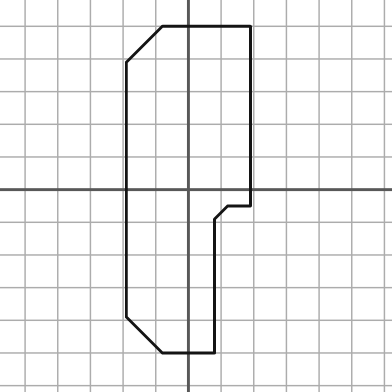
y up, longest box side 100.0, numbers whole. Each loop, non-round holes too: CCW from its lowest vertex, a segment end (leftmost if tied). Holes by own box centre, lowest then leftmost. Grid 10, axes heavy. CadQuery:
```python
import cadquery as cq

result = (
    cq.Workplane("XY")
    .moveTo(-8.0, -50.0)
    .lineTo(8.0, -50.0)
    .lineTo(8.0, -9.0)
    .lineTo(12.0, -5.0)
    .lineTo(19.0, -5.0)
    .lineTo(19.0, 50.0)
    .lineTo(-8.0, 50.0)
    .lineTo(-19.0, 39.0)
    .lineTo(-19.0, -39.0)
    .close()
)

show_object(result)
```